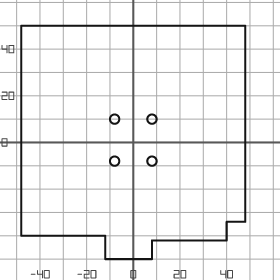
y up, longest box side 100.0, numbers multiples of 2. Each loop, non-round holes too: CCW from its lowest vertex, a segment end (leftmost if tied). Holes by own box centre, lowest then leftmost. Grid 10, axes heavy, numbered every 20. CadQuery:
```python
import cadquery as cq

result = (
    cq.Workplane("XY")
    .moveTo(-12.0, -50.0)
    .lineTo(8.0, -50.0)
    .lineTo(8.0, -42.0)
    .lineTo(40.0, -42.0)
    .lineTo(40.0, -34.0)
    .lineTo(48.0, -34.0)
    .lineTo(48.0, 50.0)
    .lineTo(-48.0, 50.0)
    .lineTo(-48.0, -40.0)
    .lineTo(-12.0, -40.0)
    .close()
    .moveTo(-8.0, -8.0)
    .circle(2.0)
    .moveTo(8.0, -8.0)
    .circle(2.0)
    .moveTo(-8.0, 10.0)
    .circle(2.0)
    .moveTo(8.0, 10.0)
    .circle(2.0)
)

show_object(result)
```